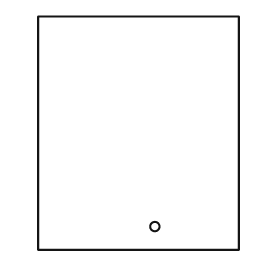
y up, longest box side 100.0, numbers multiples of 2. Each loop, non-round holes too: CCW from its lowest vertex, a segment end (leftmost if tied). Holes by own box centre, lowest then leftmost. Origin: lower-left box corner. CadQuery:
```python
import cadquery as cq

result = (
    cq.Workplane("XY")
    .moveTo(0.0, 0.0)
    .lineTo(86.0, 0.0)
    .lineTo(86.0, 100.0)
    .lineTo(0.0, 100.0)
    .close()
    .moveTo(50.0, 10.0)
    .circle(2.0)
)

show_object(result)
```